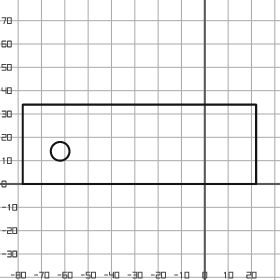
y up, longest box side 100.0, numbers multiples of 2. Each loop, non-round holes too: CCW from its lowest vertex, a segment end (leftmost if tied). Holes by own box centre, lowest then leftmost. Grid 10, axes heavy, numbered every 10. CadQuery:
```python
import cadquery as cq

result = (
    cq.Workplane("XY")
    .moveTo(-78.0, 0.0)
    .lineTo(22.0, 0.0)
    .lineTo(22.0, 34.0)
    .lineTo(-78.0, 34.0)
    .close()
    .moveTo(-62.0, 14.0)
    .circle(4.0)
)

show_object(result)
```